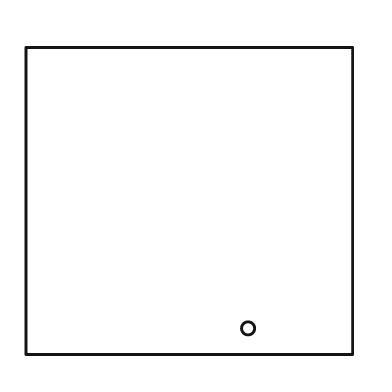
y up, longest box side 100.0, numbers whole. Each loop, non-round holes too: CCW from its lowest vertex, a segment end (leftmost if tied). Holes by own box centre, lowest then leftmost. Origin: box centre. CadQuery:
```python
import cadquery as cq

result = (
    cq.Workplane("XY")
    .moveTo(-50.0, -47.0)
    .lineTo(50.0, -47.0)
    .lineTo(50.0, 47.0)
    .lineTo(-50.0, 47.0)
    .close()
    .moveTo(18.0, -39.0)
    .circle(2.0)
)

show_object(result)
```